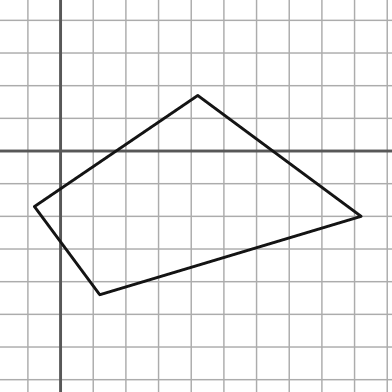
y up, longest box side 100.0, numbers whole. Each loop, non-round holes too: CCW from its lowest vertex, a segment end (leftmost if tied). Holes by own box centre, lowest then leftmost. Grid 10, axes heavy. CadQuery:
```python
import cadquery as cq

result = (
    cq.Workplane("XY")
    .moveTo(12.0, -44.0)
    .lineTo(92.0, -20.0)
    .lineTo(42.0, 17.0)
    .lineTo(-8.0, -17.0)
    .close()
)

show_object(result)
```